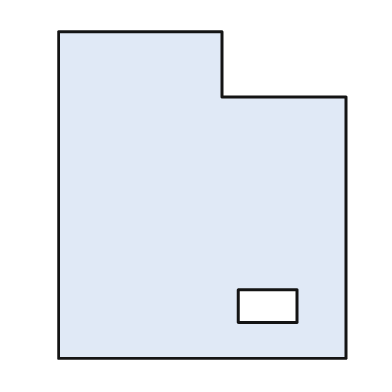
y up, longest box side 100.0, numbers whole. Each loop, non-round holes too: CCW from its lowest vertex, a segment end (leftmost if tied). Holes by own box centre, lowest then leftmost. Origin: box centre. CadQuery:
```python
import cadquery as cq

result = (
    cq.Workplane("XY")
    .moveTo(-44.0, -50.0)
    .lineTo(44.0, -50.0)
    .lineTo(44.0, 30.0)
    .lineTo(6.0, 30.0)
    .lineTo(6.0, 50.0)
    .lineTo(-44.0, 50.0)
    .close()
    .moveTo(11.0, -39.0)
    .lineTo(29.0, -39.0)
    .lineTo(29.0, -29.0)
    .lineTo(11.0, -29.0)
    .close()
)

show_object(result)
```